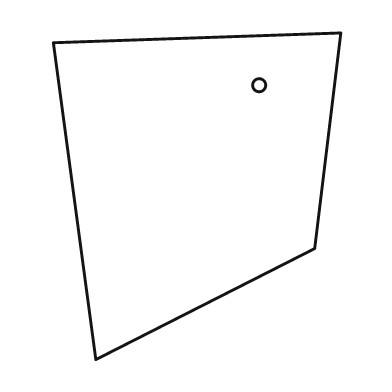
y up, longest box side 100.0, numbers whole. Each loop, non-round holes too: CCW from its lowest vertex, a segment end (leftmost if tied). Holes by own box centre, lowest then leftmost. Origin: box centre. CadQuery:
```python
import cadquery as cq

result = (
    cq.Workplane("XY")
    .moveTo(-31.0, -50.0)
    .lineTo(36.0, -16.0)
    .lineTo(44.0, 50.0)
    .lineTo(-44.0, 47.0)
    .close()
    .moveTo(19.0, 34.0)
    .circle(2.0)
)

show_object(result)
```